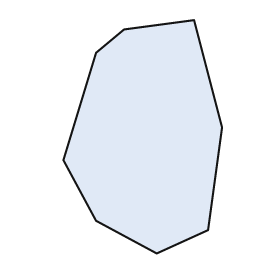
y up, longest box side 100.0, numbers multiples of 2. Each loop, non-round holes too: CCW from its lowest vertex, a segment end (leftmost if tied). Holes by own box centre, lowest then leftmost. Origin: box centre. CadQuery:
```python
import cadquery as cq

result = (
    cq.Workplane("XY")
    .moveTo(6.0, -50.0)
    .lineTo(28.0, -40.0)
    .lineTo(34.0, 4.0)
    .lineTo(22.0, 50.0)
    .lineTo(-8.0, 46.0)
    .lineTo(-20.0, 36.0)
    .lineTo(-34.0, -10.0)
    .lineTo(-20.0, -36.0)
    .close()
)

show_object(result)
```